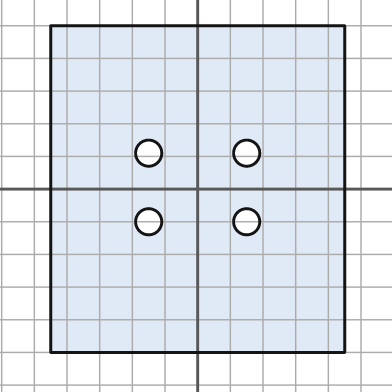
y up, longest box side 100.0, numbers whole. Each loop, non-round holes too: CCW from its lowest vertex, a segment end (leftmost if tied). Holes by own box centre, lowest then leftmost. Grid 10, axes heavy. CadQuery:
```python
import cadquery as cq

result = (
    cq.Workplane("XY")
    .moveTo(-45.0, -50.0)
    .lineTo(45.0, -50.0)
    .lineTo(45.0, 50.0)
    .lineTo(-45.0, 50.0)
    .close()
    .moveTo(-15.0, -10.0)
    .circle(4.0)
    .moveTo(15.0, -10.0)
    .circle(4.0)
    .moveTo(-15.0, 11.0)
    .circle(4.0)
    .moveTo(15.0, 11.0)
    .circle(4.0)
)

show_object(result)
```